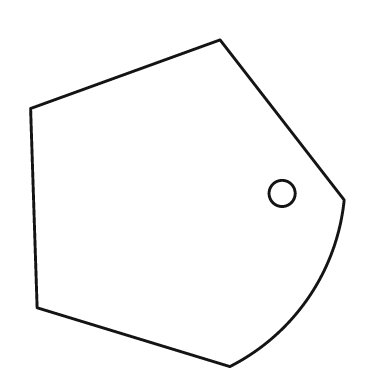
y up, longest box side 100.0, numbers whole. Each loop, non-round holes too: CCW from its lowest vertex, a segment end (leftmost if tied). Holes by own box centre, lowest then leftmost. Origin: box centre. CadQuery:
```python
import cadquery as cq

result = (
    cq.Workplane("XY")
    .moveTo(13.0, -50.0)
    .threePointArc((37.0, -29.0), (48.0, 1.0))
    .lineTo(10.0, 50.0)
    .lineTo(-48.0, 29.0)
    .lineTo(-46.0, -32.0)
    .close()
    .moveTo(29.0, 3.0)
    .circle(4.0)
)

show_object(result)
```